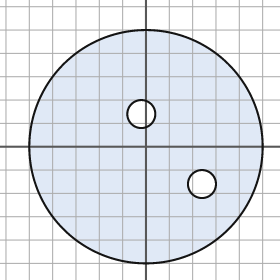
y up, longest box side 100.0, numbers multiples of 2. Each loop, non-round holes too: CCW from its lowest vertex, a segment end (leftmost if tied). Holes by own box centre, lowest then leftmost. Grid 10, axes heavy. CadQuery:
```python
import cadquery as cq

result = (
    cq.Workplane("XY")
    .moveTo(0.0, 0.0)
    .circle(50.0)
    .moveTo(24.0, -16.0)
    .circle(6.0)
    .moveTo(-2.0, 14.0)
    .circle(6.0)
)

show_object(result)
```